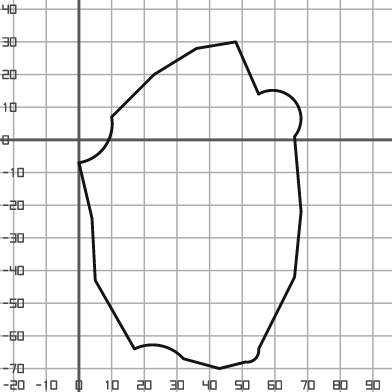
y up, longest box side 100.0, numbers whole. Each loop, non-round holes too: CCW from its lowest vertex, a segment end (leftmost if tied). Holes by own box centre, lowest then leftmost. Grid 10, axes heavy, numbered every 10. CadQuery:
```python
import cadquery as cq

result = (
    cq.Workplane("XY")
    .moveTo(43.0, -70.0)
    .lineTo(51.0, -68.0)
    .threePointArc((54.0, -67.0), (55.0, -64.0))
    .lineTo(66.0, -42.0)
    .lineTo(68.0, -22.0)
    .lineTo(66.0, 1.0)
    .threePointArc((66.0, 12.0), (55.0, 14.0))
    .lineTo(48.0, 30.0)
    .lineTo(36.0, 28.0)
    .lineTo(23.0, 20.0)
    .lineTo(10.0, 7.0)
    .threePointArc((8.0, -2.0), (0.0, -7.0))
    .lineTo(4.0, -24.0)
    .lineTo(5.0, -43.0)
    .lineTo(17.0, -64.0)
    .threePointArc((25.0, -63.0), (32.0, -67.0))
    .close()
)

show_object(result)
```